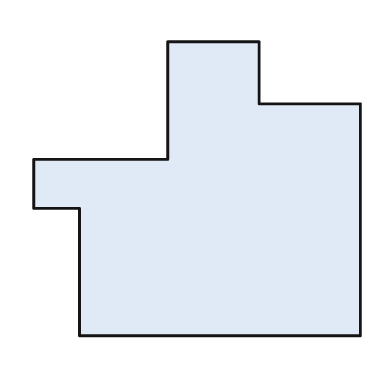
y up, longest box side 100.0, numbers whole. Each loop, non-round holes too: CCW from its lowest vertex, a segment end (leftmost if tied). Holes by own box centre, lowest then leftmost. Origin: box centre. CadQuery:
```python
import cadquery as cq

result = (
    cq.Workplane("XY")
    .moveTo(-36.0, -45.0)
    .lineTo(50.0, -45.0)
    .lineTo(50.0, 26.0)
    .lineTo(19.0, 26.0)
    .lineTo(19.0, 45.0)
    .lineTo(-9.0, 45.0)
    .lineTo(-9.0, 9.0)
    .lineTo(-50.0, 9.0)
    .lineTo(-50.0, -6.0)
    .lineTo(-36.0, -6.0)
    .close()
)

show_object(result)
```